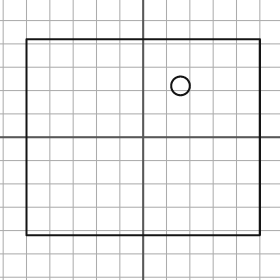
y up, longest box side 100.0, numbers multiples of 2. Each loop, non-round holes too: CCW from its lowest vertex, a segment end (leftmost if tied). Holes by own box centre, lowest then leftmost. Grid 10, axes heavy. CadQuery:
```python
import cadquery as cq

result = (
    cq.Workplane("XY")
    .moveTo(-50.0, -42.0)
    .lineTo(50.0, -42.0)
    .lineTo(50.0, 42.0)
    .lineTo(-50.0, 42.0)
    .close()
    .moveTo(16.0, 22.0)
    .circle(4.0)
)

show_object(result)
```